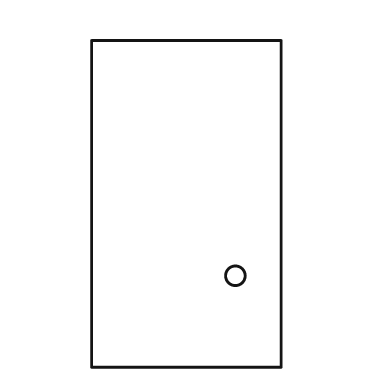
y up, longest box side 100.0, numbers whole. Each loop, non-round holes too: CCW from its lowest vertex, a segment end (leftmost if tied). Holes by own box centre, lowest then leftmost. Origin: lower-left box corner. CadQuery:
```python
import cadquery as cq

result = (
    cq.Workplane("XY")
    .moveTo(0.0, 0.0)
    .lineTo(58.0, 0.0)
    .lineTo(58.0, 100.0)
    .lineTo(0.0, 100.0)
    .close()
    .moveTo(44.0, 28.0)
    .circle(3.0)
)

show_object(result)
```